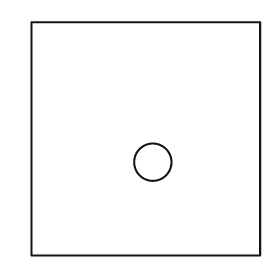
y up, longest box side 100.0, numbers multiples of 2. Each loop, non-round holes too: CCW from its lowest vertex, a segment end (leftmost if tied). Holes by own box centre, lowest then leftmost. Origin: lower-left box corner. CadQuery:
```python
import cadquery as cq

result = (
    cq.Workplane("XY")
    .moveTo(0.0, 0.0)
    .lineTo(98.0, 0.0)
    .lineTo(98.0, 100.0)
    .lineTo(0.0, 100.0)
    .close()
    .moveTo(52.0, 40.0)
    .circle(8.0)
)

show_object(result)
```